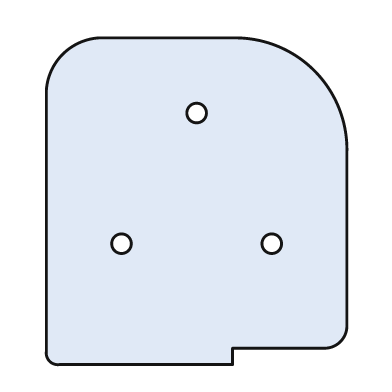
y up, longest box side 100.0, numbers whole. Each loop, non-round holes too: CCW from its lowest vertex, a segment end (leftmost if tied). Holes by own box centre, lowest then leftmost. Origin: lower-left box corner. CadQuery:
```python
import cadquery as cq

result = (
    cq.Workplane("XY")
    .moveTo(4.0, 0.0)
    .lineTo(57.0, 0.0)
    .lineTo(57.0, 5.0)
    .lineTo(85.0, 5.0)
    .threePointArc((90.0, 7.0), (92.0, 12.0))
    .lineTo(92.0, 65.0)
    .threePointArc((82.0, 90.0), (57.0, 100.0))
    .lineTo(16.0, 100.0)
    .threePointArc((5.0, 95.0), (0.0, 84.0))
    .lineTo(0.0, 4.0)
    .threePointArc((1.0, 1.0), (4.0, 0.0))
    .close()
    .moveTo(23.0, 37.0)
    .circle(3.0)
    .moveTo(69.0, 37.0)
    .circle(3.0)
    .moveTo(46.0, 77.0)
    .circle(3.0)
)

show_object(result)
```